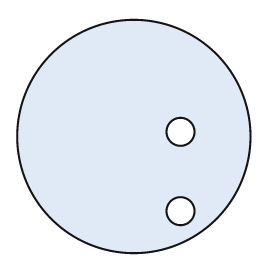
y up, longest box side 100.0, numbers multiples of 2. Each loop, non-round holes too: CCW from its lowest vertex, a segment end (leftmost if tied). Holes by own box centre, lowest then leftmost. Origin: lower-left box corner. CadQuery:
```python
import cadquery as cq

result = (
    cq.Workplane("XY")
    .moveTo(50.0, 50.0)
    .circle(50.0)
    .moveTo(70.0, 18.0)
    .circle(6.0)
    .moveTo(70.0, 52.0)
    .circle(6.0)
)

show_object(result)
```